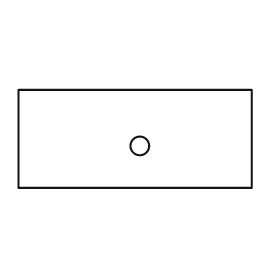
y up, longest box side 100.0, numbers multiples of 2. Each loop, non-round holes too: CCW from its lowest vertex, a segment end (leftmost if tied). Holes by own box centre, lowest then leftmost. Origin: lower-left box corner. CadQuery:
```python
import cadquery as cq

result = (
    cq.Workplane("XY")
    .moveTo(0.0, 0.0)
    .lineTo(100.0, 0.0)
    .lineTo(100.0, 42.0)
    .lineTo(0.0, 42.0)
    .close()
    .moveTo(52.0, 18.0)
    .circle(4.0)
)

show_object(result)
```